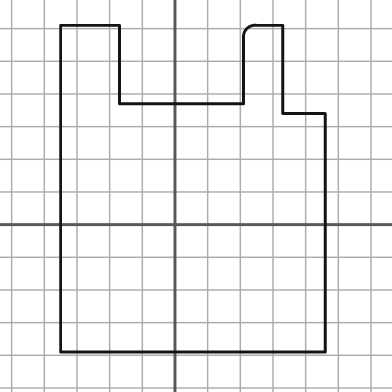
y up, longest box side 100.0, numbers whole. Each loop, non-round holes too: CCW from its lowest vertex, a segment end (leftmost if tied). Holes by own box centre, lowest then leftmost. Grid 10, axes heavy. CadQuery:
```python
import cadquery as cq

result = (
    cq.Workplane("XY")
    .moveTo(-35.0, -39.0)
    .lineTo(46.0, -39.0)
    .lineTo(46.0, 34.0)
    .lineTo(33.0, 34.0)
    .lineTo(33.0, 61.0)
    .lineTo(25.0, 61.0)
    .threePointArc((22.0, 60.0), (21.0, 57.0))
    .lineTo(21.0, 37.0)
    .lineTo(-17.0, 37.0)
    .lineTo(-17.0, 61.0)
    .lineTo(-35.0, 61.0)
    .close()
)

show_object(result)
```